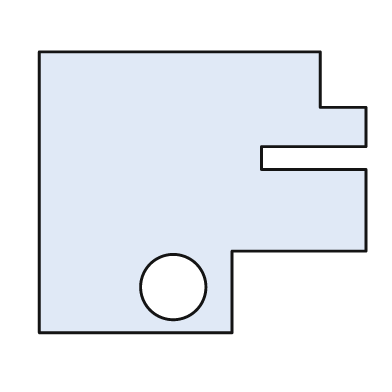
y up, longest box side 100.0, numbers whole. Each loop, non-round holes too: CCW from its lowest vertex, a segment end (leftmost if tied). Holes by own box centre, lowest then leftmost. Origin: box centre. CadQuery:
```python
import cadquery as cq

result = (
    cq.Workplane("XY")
    .moveTo(-50.0, -43.0)
    .lineTo(9.0, -43.0)
    .lineTo(9.0, -18.0)
    .lineTo(50.0, -18.0)
    .lineTo(50.0, 7.0)
    .lineTo(18.0, 7.0)
    .lineTo(18.0, 14.0)
    .lineTo(50.0, 14.0)
    .lineTo(50.0, 26.0)
    .lineTo(36.0, 26.0)
    .lineTo(36.0, 43.0)
    .lineTo(-50.0, 43.0)
    .close()
    .moveTo(-9.0, -29.0)
    .circle(10.0)
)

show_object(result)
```